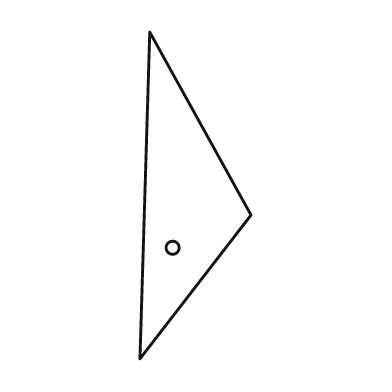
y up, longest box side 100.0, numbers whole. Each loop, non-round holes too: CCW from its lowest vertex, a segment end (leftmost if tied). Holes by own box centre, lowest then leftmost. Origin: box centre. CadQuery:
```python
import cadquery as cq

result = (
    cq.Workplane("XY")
    .moveTo(-17.0, -50.0)
    .lineTo(17.0, -6.0)
    .lineTo(-14.0, 50.0)
    .close()
    .moveTo(-7.0, -16.0)
    .circle(2.0)
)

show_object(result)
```